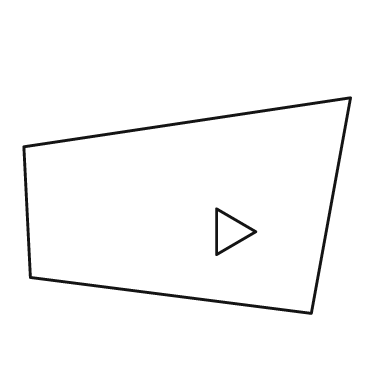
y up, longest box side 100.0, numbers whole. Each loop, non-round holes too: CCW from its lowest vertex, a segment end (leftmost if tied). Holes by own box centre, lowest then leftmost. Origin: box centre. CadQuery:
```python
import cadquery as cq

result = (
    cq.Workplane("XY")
    .moveTo(38.0, -33.0)
    .lineTo(50.0, 33.0)
    .lineTo(-50.0, 18.0)
    .lineTo(-48.0, -22.0)
    .close()
    .moveTo(9.0, -15.0)
    .lineTo(21.0, -8.0)
    .lineTo(9.0, -1.0)
    .close()
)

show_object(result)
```